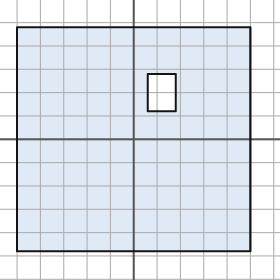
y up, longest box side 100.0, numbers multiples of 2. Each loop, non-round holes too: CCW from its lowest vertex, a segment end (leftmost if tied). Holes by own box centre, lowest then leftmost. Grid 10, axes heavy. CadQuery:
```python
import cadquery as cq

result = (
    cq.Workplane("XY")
    .moveTo(-50.0, -48.0)
    .lineTo(50.0, -48.0)
    .lineTo(50.0, 48.0)
    .lineTo(-50.0, 48.0)
    .close()
    .moveTo(6.0, 12.0)
    .lineTo(18.0, 12.0)
    .lineTo(18.0, 28.0)
    .lineTo(6.0, 28.0)
    .close()
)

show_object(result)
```